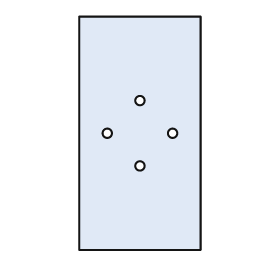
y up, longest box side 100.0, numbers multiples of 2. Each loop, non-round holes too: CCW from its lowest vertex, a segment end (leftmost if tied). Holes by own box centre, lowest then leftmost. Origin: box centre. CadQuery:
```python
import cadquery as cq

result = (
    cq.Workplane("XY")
    .moveTo(-26.0, -50.0)
    .lineTo(26.0, -50.0)
    .lineTo(26.0, 50.0)
    .lineTo(-26.0, 50.0)
    .close()
    .moveTo(0.0, -14.0)
    .circle(2.0)
    .moveTo(-14.0, 0.0)
    .circle(2.0)
    .moveTo(14.0, 0.0)
    .circle(2.0)
    .moveTo(0.0, 14.0)
    .circle(2.0)
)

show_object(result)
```